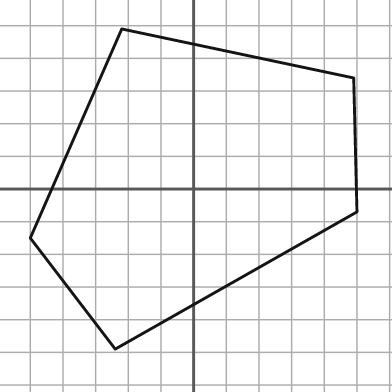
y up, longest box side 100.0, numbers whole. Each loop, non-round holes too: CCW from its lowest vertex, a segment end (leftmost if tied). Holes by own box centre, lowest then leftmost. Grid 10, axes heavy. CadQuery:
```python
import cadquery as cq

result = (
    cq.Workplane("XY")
    .moveTo(-24.0, -49.0)
    .lineTo(50.0, -7.0)
    .lineTo(49.0, 34.0)
    .lineTo(-22.0, 49.0)
    .lineTo(-50.0, -15.0)
    .close()
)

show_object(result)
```